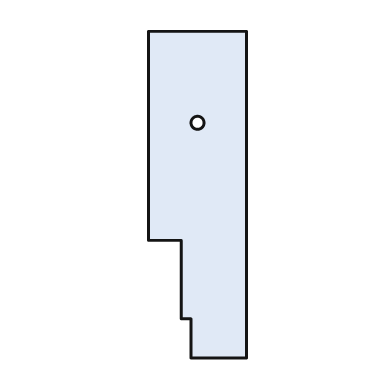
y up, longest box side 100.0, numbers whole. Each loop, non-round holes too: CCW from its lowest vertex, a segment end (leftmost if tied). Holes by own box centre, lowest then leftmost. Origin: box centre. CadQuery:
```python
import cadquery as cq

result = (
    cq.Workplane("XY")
    .moveTo(-2.0, -50.0)
    .lineTo(15.0, -50.0)
    .lineTo(15.0, 50.0)
    .lineTo(-15.0, 50.0)
    .lineTo(-15.0, -14.0)
    .lineTo(-5.0, -14.0)
    .lineTo(-5.0, -38.0)
    .lineTo(-2.0, -38.0)
    .close()
    .moveTo(0.0, 22.0)
    .circle(2.0)
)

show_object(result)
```